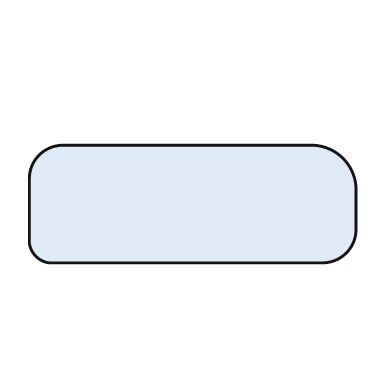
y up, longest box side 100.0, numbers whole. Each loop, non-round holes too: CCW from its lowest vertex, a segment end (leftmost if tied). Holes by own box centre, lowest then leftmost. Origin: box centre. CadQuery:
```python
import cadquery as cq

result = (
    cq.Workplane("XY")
    .moveTo(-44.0, -18.0)
    .lineTo(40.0, -18.0)
    .threePointArc((47.0, -15.0), (50.0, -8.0))
    .lineTo(50.0, 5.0)
    .threePointArc((46.0, 14.0), (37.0, 18.0))
    .lineTo(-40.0, 18.0)
    .threePointArc((-47.0, 15.0), (-50.0, 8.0))
    .lineTo(-50.0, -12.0)
    .threePointArc((-48.0, -16.0), (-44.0, -18.0))
    .close()
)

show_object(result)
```